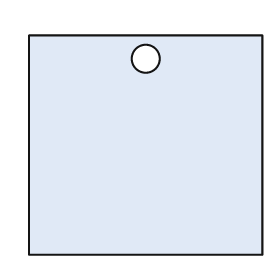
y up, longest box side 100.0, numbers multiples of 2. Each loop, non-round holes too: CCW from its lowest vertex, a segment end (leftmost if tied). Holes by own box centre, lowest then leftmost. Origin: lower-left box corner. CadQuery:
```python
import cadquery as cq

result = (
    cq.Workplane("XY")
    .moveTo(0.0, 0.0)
    .lineTo(100.0, 0.0)
    .lineTo(100.0, 94.0)
    .lineTo(0.0, 94.0)
    .close()
    .moveTo(50.0, 84.0)
    .circle(6.0)
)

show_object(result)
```